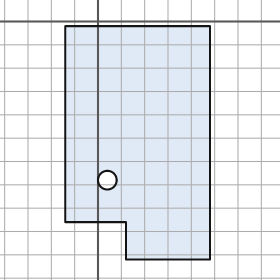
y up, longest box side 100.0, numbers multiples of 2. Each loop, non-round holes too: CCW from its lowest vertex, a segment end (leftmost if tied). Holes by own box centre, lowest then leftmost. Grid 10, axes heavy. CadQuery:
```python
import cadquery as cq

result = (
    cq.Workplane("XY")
    .moveTo(12.0, -102.0)
    .lineTo(48.0, -102.0)
    .lineTo(48.0, -2.0)
    .lineTo(-14.0, -2.0)
    .lineTo(-14.0, -86.0)
    .lineTo(12.0, -86.0)
    .close()
    .moveTo(4.0, -68.0)
    .circle(4.0)
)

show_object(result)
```